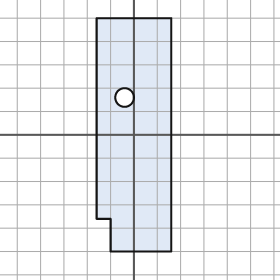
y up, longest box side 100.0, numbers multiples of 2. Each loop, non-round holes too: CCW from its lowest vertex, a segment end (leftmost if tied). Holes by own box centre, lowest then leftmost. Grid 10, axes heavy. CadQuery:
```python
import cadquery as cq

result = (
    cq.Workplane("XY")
    .moveTo(-10.0, -50.0)
    .lineTo(16.0, -50.0)
    .lineTo(16.0, 50.0)
    .lineTo(-16.0, 50.0)
    .lineTo(-16.0, -36.0)
    .lineTo(-10.0, -36.0)
    .close()
    .moveTo(-4.0, 16.0)
    .circle(4.0)
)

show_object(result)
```